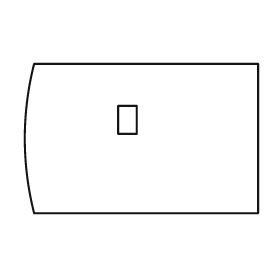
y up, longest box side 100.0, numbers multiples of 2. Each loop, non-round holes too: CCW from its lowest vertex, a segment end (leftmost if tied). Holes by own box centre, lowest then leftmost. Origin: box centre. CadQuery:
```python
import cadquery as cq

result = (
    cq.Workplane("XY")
    .moveTo(-46.0, -32.0)
    .lineTo(50.0, -32.0)
    .lineTo(50.0, 32.0)
    .lineTo(-46.0, 32.0)
    .threePointArc((-50.0, 0.0), (-46.0, -32.0))
    .close()
    .moveTo(-10.0, 2.0)
    .lineTo(-2.0, 2.0)
    .lineTo(-2.0, 14.0)
    .lineTo(-10.0, 14.0)
    .close()
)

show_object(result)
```